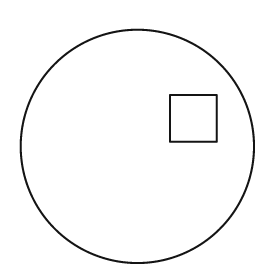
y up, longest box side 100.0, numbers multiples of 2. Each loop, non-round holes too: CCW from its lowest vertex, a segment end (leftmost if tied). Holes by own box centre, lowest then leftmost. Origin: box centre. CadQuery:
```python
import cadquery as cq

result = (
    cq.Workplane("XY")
    .moveTo(0.0, 0.0)
    .circle(50.0)
    .moveTo(14.0, 2.0)
    .lineTo(34.0, 2.0)
    .lineTo(34.0, 22.0)
    .lineTo(14.0, 22.0)
    .close()
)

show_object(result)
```